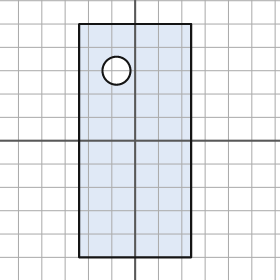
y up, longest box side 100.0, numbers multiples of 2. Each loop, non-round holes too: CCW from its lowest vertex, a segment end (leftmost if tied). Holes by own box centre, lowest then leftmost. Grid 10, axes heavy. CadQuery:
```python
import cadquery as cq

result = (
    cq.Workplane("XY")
    .moveTo(-24.0, -50.0)
    .lineTo(24.0, -50.0)
    .lineTo(24.0, 50.0)
    .lineTo(-24.0, 50.0)
    .close()
    .moveTo(-8.0, 30.0)
    .circle(6.0)
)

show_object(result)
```